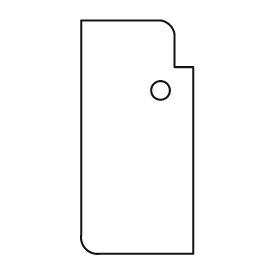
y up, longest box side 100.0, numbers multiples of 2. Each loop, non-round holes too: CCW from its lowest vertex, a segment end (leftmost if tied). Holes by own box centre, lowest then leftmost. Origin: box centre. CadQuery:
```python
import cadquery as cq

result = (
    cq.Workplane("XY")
    .moveTo(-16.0, -50.0)
    .lineTo(24.0, -50.0)
    .lineTo(24.0, 30.0)
    .lineTo(16.0, 30.0)
    .lineTo(16.0, 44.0)
    .threePointArc((14.0, 48.0), (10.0, 50.0))
    .lineTo(-24.0, 50.0)
    .lineTo(-24.0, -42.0)
    .threePointArc((-22.0, -48.0), (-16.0, -50.0))
    .close()
    .moveTo(10.0, 20.0)
    .circle(4.0)
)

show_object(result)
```